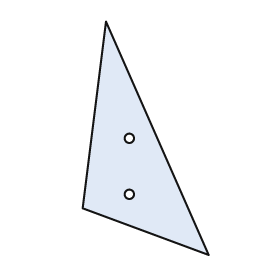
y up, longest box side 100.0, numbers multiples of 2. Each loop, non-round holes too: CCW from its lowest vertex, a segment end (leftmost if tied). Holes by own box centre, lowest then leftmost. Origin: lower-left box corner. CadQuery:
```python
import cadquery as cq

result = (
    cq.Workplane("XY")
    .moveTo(54.0, 0.0)
    .lineTo(10.0, 100.0)
    .lineTo(0.0, 20.0)
    .close()
    .moveTo(20.0, 26.0)
    .circle(2.0)
    .moveTo(20.0, 50.0)
    .circle(2.0)
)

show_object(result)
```